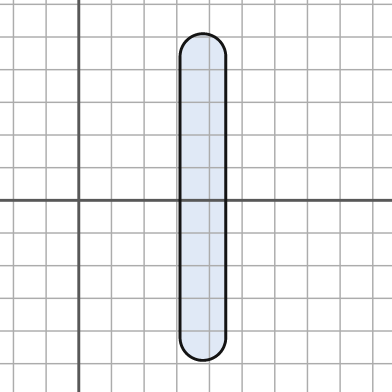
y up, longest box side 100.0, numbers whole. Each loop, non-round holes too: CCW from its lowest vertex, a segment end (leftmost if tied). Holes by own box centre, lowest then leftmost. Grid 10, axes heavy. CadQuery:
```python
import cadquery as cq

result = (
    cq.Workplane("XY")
    .moveTo(31.0, -42.0)
    .threePointArc((38.0, -49.0), (45.0, -42.0))
    .lineTo(45.0, 44.0)
    .threePointArc((38.0, 51.0), (31.0, 44.0))
    .close()
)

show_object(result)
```